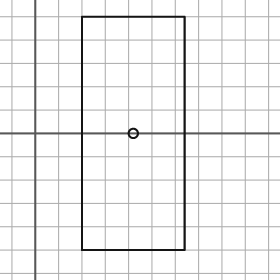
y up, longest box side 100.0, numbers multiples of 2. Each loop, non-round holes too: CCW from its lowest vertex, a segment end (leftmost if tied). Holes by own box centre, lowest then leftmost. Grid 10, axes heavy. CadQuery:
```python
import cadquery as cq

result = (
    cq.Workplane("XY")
    .moveTo(20.0, -50.0)
    .lineTo(64.0, -50.0)
    .lineTo(64.0, 50.0)
    .lineTo(20.0, 50.0)
    .close()
    .moveTo(42.0, 0.0)
    .circle(2.0)
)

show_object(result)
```